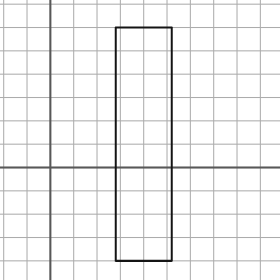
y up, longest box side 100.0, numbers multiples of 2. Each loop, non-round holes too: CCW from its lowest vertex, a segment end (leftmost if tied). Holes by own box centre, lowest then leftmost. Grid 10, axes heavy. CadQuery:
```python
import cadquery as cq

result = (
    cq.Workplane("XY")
    .moveTo(28.0, -40.0)
    .lineTo(52.0, -40.0)
    .lineTo(52.0, 60.0)
    .lineTo(28.0, 60.0)
    .close()
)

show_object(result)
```